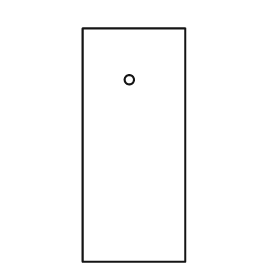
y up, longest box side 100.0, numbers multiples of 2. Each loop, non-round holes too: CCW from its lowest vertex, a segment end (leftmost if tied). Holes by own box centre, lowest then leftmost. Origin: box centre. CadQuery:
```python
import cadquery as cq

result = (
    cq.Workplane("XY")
    .moveTo(-22.0, -50.0)
    .lineTo(22.0, -50.0)
    .lineTo(22.0, 50.0)
    .lineTo(-22.0, 50.0)
    .close()
    .moveTo(-2.0, 28.0)
    .circle(2.0)
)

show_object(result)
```